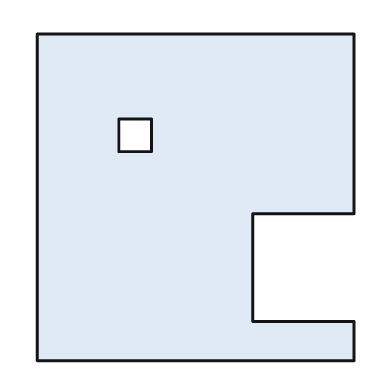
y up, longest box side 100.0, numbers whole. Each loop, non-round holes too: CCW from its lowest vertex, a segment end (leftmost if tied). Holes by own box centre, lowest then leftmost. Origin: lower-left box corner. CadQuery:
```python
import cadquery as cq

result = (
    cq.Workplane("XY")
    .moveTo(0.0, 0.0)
    .lineTo(97.0, 0.0)
    .lineTo(97.0, 12.0)
    .lineTo(66.0, 12.0)
    .lineTo(66.0, 45.0)
    .lineTo(97.0, 45.0)
    .lineTo(97.0, 100.0)
    .lineTo(0.0, 100.0)
    .close()
    .moveTo(25.0, 64.0)
    .lineTo(35.0, 64.0)
    .lineTo(35.0, 74.0)
    .lineTo(25.0, 74.0)
    .close()
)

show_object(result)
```